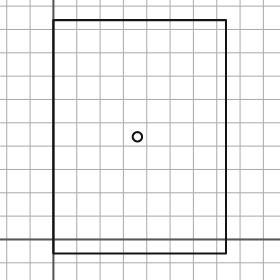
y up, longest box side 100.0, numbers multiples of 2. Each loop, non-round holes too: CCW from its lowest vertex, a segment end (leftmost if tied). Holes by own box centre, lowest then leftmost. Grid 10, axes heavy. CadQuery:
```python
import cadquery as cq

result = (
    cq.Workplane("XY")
    .moveTo(0.0, -6.0)
    .lineTo(74.0, -6.0)
    .lineTo(74.0, 94.0)
    .lineTo(0.0, 94.0)
    .close()
    .moveTo(36.0, 44.0)
    .circle(2.0)
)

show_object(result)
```